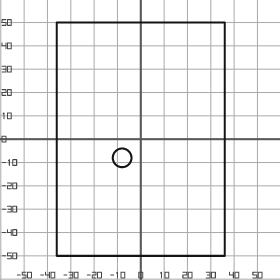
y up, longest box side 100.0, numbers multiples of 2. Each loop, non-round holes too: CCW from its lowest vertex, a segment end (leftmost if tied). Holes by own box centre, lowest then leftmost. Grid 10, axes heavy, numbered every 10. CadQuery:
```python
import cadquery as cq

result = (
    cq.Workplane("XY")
    .moveTo(-36.0, -50.0)
    .lineTo(36.0, -50.0)
    .lineTo(36.0, 50.0)
    .lineTo(-36.0, 50.0)
    .close()
    .moveTo(-8.0, -8.0)
    .circle(4.0)
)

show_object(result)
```